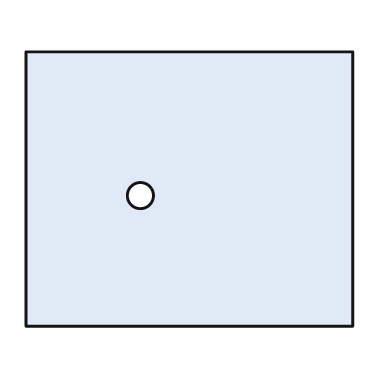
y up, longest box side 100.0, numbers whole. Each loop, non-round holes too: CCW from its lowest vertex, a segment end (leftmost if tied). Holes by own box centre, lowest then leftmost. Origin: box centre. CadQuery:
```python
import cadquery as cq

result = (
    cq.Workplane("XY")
    .moveTo(-50.0, -42.0)
    .lineTo(50.0, -42.0)
    .lineTo(50.0, 42.0)
    .lineTo(-50.0, 42.0)
    .close()
    .moveTo(-15.0, -2.0)
    .circle(4.0)
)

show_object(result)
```